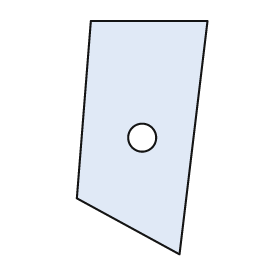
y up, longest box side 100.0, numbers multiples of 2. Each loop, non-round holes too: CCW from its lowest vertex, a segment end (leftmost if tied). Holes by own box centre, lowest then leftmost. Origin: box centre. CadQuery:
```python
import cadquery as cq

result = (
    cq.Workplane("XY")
    .moveTo(16.0, -50.0)
    .lineTo(28.0, 50.0)
    .lineTo(-22.0, 50.0)
    .lineTo(-28.0, -26.0)
    .close()
    .moveTo(0.0, 0.0)
    .circle(6.0)
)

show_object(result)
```